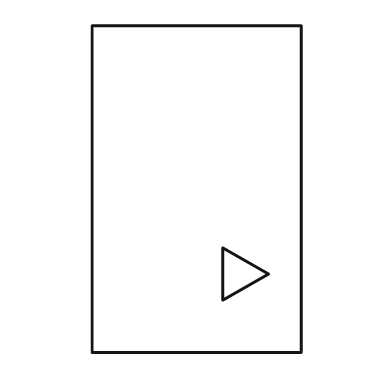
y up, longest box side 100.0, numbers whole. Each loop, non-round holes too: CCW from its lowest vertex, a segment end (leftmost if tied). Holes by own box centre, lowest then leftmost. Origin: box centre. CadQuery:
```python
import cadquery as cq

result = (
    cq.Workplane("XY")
    .moveTo(-32.0, -50.0)
    .lineTo(32.0, -50.0)
    .lineTo(32.0, 50.0)
    .lineTo(-32.0, 50.0)
    .close()
    .moveTo(8.0, -34.0)
    .lineTo(22.0, -26.0)
    .lineTo(8.0, -18.0)
    .close()
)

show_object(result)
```